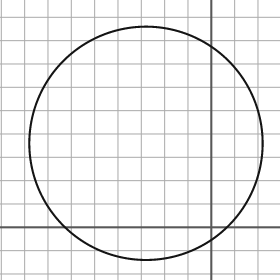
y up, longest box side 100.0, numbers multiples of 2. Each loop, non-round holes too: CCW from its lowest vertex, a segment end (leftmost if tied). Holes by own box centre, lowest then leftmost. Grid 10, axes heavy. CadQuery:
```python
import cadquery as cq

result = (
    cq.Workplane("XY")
    .moveTo(-28.0, 36.0)
    .circle(50.0)
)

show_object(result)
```